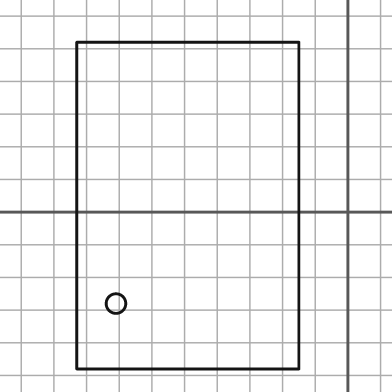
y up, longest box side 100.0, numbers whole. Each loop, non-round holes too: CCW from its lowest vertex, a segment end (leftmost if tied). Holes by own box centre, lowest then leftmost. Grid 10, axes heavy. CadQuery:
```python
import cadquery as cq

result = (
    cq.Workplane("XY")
    .moveTo(-83.0, -48.0)
    .lineTo(-15.0, -48.0)
    .lineTo(-15.0, 52.0)
    .lineTo(-83.0, 52.0)
    .close()
    .moveTo(-71.0, -28.0)
    .circle(3.0)
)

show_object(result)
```